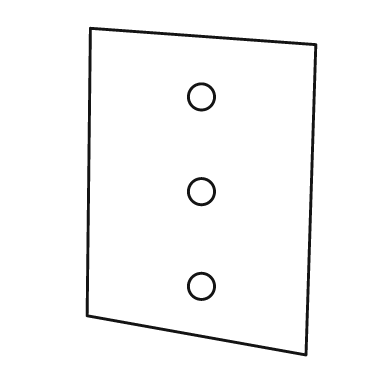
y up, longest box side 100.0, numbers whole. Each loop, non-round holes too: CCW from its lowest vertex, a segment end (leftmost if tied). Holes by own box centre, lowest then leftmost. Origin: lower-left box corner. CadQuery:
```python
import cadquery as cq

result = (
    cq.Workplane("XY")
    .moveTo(67.0, 0.0)
    .lineTo(70.0, 95.0)
    .lineTo(1.0, 100.0)
    .lineTo(0.0, 12.0)
    .close()
    .moveTo(35.0, 21.0)
    .circle(4.0)
    .moveTo(35.0, 50.0)
    .circle(4.0)
    .moveTo(35.0, 79.0)
    .circle(4.0)
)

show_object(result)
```